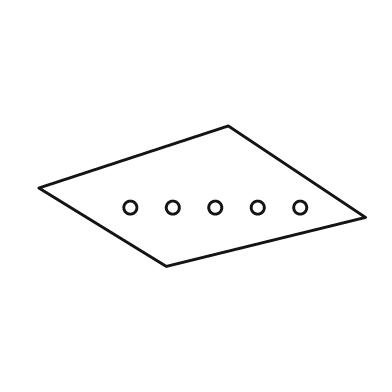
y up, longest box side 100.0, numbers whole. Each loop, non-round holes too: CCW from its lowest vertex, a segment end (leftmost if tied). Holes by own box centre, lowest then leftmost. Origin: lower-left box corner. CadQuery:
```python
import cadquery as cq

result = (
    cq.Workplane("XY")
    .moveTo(39.0, 0.0)
    .lineTo(100.0, 15.0)
    .lineTo(58.0, 43.0)
    .lineTo(0.0, 24.0)
    .close()
    .moveTo(28.0, 18.0)
    .circle(2.0)
    .moveTo(41.0, 18.0)
    .circle(2.0)
    .moveTo(54.0, 18.0)
    .circle(2.0)
    .moveTo(67.0, 18.0)
    .circle(2.0)
    .moveTo(80.0, 18.0)
    .circle(2.0)
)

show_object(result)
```